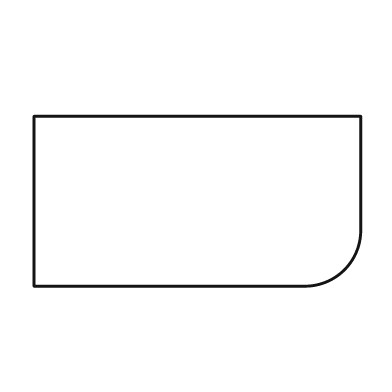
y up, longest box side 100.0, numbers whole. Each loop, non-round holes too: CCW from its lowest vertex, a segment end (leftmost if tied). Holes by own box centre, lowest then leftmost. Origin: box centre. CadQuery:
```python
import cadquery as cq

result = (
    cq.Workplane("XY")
    .moveTo(-50.0, -26.0)
    .lineTo(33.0, -26.0)
    .threePointArc((45.0, -21.0), (50.0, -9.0))
    .lineTo(50.0, 26.0)
    .lineTo(-50.0, 26.0)
    .close()
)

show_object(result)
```